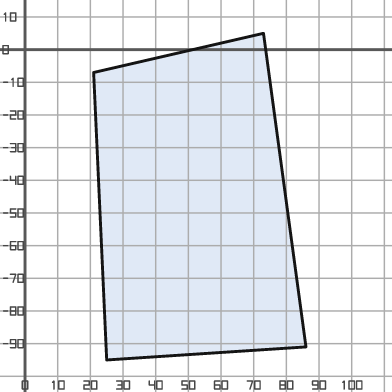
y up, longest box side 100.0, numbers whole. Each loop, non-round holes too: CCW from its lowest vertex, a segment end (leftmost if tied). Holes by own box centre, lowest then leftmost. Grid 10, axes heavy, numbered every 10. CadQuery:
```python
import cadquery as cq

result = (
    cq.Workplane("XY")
    .moveTo(25.0, -95.0)
    .lineTo(86.0, -91.0)
    .lineTo(73.0, 5.0)
    .lineTo(21.0, -7.0)
    .close()
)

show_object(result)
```